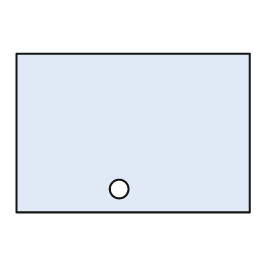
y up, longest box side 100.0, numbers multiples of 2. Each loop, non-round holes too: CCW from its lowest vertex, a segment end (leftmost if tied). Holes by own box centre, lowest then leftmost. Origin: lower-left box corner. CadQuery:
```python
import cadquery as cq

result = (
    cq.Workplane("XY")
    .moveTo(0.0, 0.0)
    .lineTo(100.0, 0.0)
    .lineTo(100.0, 68.0)
    .lineTo(0.0, 68.0)
    .close()
    .moveTo(44.0, 10.0)
    .circle(4.0)
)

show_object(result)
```